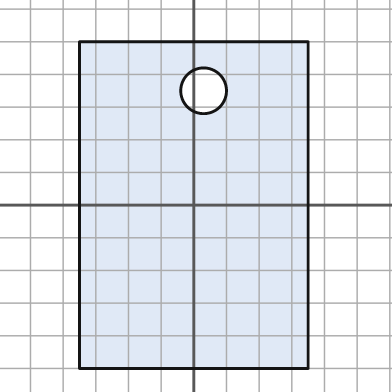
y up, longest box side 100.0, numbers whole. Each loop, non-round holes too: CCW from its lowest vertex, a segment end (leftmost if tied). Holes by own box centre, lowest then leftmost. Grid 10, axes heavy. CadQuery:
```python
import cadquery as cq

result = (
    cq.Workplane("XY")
    .moveTo(-35.0, -50.0)
    .lineTo(35.0, -50.0)
    .lineTo(35.0, 50.0)
    .lineTo(-35.0, 50.0)
    .close()
    .moveTo(3.0, 35.0)
    .circle(7.0)
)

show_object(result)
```